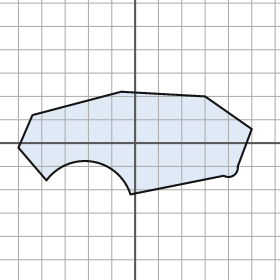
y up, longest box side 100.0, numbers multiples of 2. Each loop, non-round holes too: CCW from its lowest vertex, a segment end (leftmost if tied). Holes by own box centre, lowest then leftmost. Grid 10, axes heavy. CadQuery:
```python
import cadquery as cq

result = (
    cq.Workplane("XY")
    .moveTo(-2.0, -22.0)
    .lineTo(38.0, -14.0)
    .threePointArc((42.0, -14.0), (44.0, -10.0))
    .lineTo(50.0, 6.0)
    .lineTo(30.0, 20.0)
    .lineTo(-6.0, 22.0)
    .lineTo(-44.0, 12.0)
    .lineTo(-50.0, -2.0)
    .lineTo(-38.0, -16.0)
    .threePointArc((-18.0, -8.0), (-2.0, -22.0))
    .close()
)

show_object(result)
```